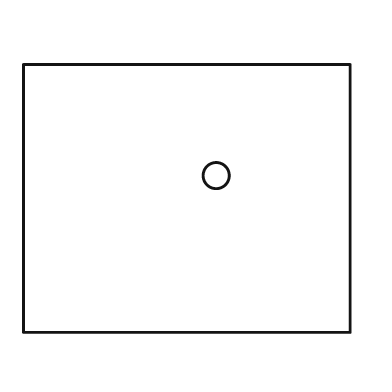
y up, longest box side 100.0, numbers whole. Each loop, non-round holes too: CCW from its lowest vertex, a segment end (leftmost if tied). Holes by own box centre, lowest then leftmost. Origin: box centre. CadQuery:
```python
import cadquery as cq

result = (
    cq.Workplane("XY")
    .moveTo(-50.0, -41.0)
    .lineTo(50.0, -41.0)
    .lineTo(50.0, 41.0)
    .lineTo(-50.0, 41.0)
    .close()
    .moveTo(9.0, 7.0)
    .circle(4.0)
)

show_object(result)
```